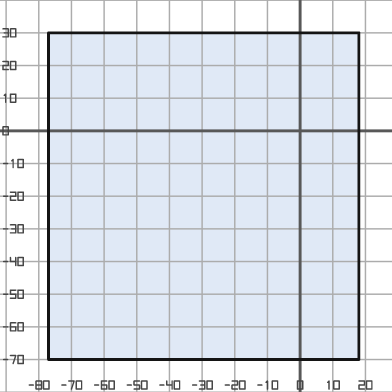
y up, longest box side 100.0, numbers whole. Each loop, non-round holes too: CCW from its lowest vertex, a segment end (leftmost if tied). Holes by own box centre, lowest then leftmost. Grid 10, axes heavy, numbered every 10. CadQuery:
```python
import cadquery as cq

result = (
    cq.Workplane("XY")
    .moveTo(-77.0, -70.0)
    .lineTo(18.0, -70.0)
    .lineTo(18.0, 30.0)
    .lineTo(-77.0, 30.0)
    .close()
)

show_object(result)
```